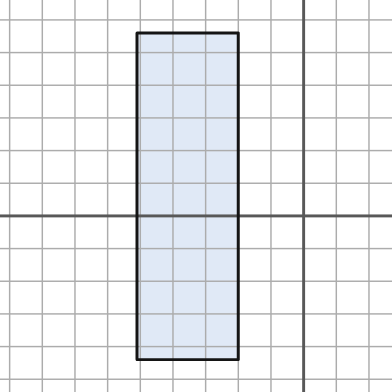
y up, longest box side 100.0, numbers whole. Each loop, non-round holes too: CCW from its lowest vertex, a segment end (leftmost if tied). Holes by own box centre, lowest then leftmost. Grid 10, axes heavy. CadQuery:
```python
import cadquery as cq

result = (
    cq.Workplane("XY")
    .moveTo(-51.0, -44.0)
    .lineTo(-20.0, -44.0)
    .lineTo(-20.0, 56.0)
    .lineTo(-51.0, 56.0)
    .close()
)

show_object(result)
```